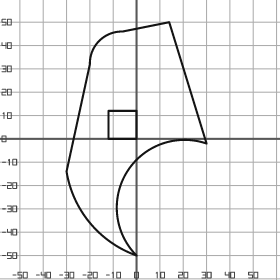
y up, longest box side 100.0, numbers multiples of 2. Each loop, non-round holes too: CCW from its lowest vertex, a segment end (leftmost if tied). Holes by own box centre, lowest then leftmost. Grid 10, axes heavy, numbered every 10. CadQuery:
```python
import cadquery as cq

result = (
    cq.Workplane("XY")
    .moveTo(0.0, -50.0)
    .threePointArc((-4.0, -14.0), (30.0, -2.0))
    .lineTo(14.0, 50.0)
    .lineTo(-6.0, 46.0)
    .threePointArc((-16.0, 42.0), (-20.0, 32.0))
    .lineTo(-30.0, -14.0)
    .threePointArc((-20.0, -36.0), (0.0, -50.0))
    .close()
    .moveTo(-12.0, 0.0)
    .lineTo(0.0, 0.0)
    .lineTo(0.0, 12.0)
    .lineTo(-12.0, 12.0)
    .close()
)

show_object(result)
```